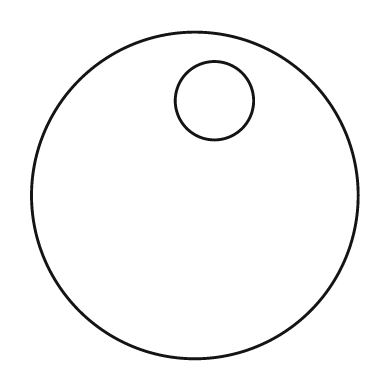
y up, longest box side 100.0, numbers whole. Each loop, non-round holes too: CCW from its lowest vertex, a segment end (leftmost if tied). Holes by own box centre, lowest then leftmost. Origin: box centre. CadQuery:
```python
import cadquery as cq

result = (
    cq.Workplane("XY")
    .moveTo(0.0, 0.0)
    .circle(50.0)
    .moveTo(6.0, 29.0)
    .circle(12.0)
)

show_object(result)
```